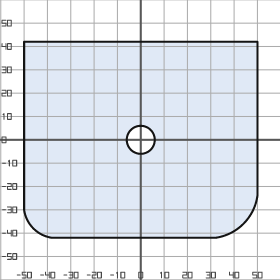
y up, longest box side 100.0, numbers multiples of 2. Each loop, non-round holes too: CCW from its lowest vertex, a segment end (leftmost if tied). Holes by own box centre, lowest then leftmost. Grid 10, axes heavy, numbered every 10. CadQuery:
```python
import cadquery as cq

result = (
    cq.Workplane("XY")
    .moveTo(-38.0, -42.0)
    .lineTo(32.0, -42.0)
    .threePointArc((44.0, -36.0), (50.0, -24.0))
    .lineTo(50.0, 42.0)
    .lineTo(-50.0, 42.0)
    .lineTo(-50.0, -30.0)
    .threePointArc((-46.0, -38.0), (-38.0, -42.0))
    .close()
    .moveTo(0.0, 0.0)
    .circle(6.0)
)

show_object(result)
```